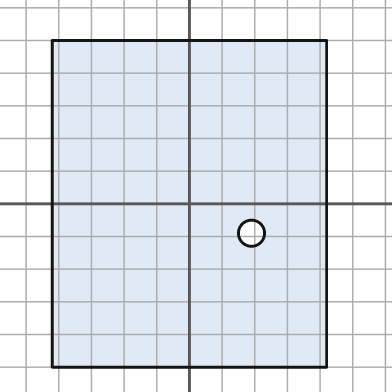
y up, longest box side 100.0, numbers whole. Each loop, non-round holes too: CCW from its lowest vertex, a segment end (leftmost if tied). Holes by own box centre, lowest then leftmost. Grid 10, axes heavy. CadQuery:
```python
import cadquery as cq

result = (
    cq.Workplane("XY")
    .moveTo(-42.0, -50.0)
    .lineTo(42.0, -50.0)
    .lineTo(42.0, 50.0)
    .lineTo(-42.0, 50.0)
    .close()
    .moveTo(19.0, -9.0)
    .circle(4.0)
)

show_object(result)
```